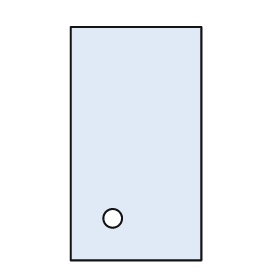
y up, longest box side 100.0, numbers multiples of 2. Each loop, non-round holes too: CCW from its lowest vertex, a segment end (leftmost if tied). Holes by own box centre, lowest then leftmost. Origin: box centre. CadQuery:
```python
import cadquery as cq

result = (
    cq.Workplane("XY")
    .moveTo(-28.0, -50.0)
    .lineTo(28.0, -50.0)
    .lineTo(28.0, 50.0)
    .lineTo(-28.0, 50.0)
    .close()
    .moveTo(-10.0, -32.0)
    .circle(4.0)
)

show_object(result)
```